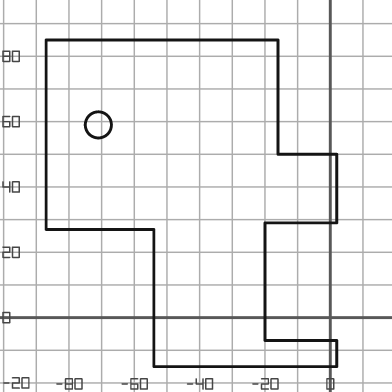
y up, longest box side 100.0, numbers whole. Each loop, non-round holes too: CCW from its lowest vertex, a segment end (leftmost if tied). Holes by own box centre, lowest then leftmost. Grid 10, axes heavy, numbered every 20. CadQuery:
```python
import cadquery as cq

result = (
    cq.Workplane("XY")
    .moveTo(-54.0, -15.0)
    .lineTo(2.0, -15.0)
    .lineTo(2.0, -7.0)
    .lineTo(-20.0, -7.0)
    .lineTo(-20.0, 29.0)
    .lineTo(2.0, 29.0)
    .lineTo(2.0, 50.0)
    .lineTo(-16.0, 50.0)
    .lineTo(-16.0, 85.0)
    .lineTo(-87.0, 85.0)
    .lineTo(-87.0, 27.0)
    .lineTo(-54.0, 27.0)
    .close()
    .moveTo(-71.0, 59.0)
    .circle(4.0)
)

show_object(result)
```